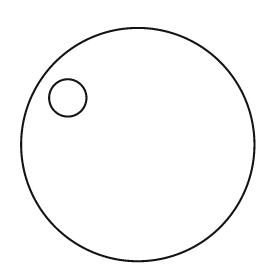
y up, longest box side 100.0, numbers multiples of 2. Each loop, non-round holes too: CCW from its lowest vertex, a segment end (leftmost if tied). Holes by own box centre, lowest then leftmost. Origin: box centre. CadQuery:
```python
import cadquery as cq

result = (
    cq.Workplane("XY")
    .moveTo(0.0, 0.0)
    .circle(50.0)
    .moveTo(-30.0, 20.0)
    .circle(8.0)
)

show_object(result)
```